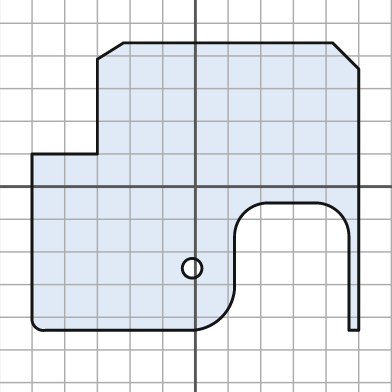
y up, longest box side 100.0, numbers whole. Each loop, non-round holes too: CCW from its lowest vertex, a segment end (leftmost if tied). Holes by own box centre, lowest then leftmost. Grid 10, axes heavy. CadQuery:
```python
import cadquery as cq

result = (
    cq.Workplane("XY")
    .moveTo(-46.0, -44.0)
    .lineTo(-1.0, -44.0)
    .threePointArc((8.0, -40.0), (12.0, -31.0))
    .lineTo(12.0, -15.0)
    .threePointArc((15.0, -8.0), (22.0, -5.0))
    .lineTo(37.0, -5.0)
    .threePointArc((44.0, -8.0), (47.0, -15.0))
    .lineTo(47.0, -44.0)
    .lineTo(50.0, -44.0)
    .lineTo(50.0, 36.0)
    .lineTo(42.0, 44.0)
    .lineTo(-22.0, 44.0)
    .lineTo(-30.0, 39.0)
    .lineTo(-30.0, 10.0)
    .lineTo(-50.0, 10.0)
    .lineTo(-50.0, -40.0)
    .threePointArc((-49.0, -43.0), (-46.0, -44.0))
    .close()
    .moveTo(-1.0, -25.0)
    .circle(3.0)
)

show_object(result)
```